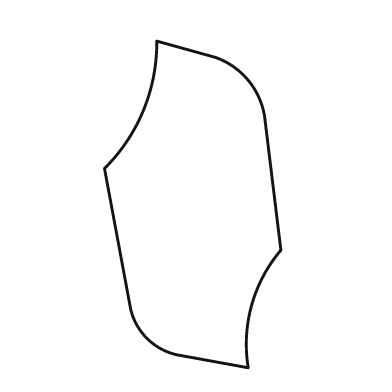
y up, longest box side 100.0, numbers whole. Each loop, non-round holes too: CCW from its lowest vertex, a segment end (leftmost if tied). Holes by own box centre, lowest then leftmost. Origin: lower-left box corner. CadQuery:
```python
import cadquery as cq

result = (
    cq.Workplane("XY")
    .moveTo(44.0, 0.0)
    .threePointArc((45.0, 19.0), (54.0, 36.0))
    .lineTo(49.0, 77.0)
    .threePointArc((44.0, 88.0), (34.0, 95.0))
    .lineTo(16.0, 100.0)
    .threePointArc((12.0, 79.0), (0.0, 61.0))
    .lineTo(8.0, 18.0)
    .threePointArc((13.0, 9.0), (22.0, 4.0))
    .close()
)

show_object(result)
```